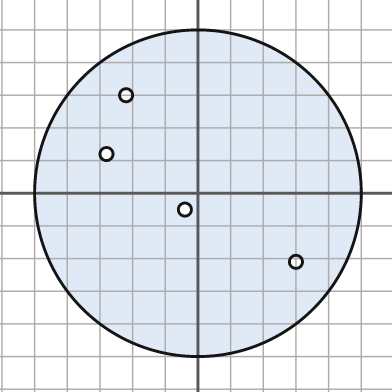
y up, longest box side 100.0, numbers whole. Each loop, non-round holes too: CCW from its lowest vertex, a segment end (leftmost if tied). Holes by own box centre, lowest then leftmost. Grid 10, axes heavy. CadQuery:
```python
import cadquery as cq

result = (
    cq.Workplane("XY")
    .moveTo(0.0, 0.0)
    .circle(50.0)
    .moveTo(30.0, -21.0)
    .circle(2.0)
    .moveTo(-4.0, -5.0)
    .circle(2.0)
    .moveTo(-28.0, 12.0)
    .circle(2.0)
    .moveTo(-22.0, 30.0)
    .circle(2.0)
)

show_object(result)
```